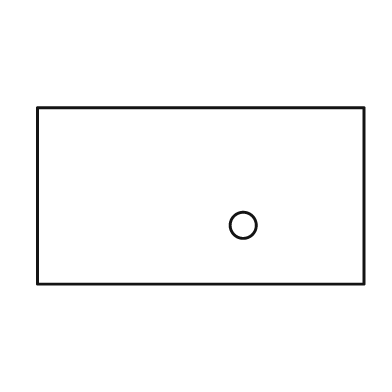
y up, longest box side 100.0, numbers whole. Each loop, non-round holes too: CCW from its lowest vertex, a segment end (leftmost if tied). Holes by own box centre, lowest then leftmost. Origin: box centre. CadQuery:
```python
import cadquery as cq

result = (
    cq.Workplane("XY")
    .moveTo(-50.0, -27.0)
    .lineTo(50.0, -27.0)
    .lineTo(50.0, 27.0)
    .lineTo(-50.0, 27.0)
    .close()
    .moveTo(13.0, -9.0)
    .circle(4.0)
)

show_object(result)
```